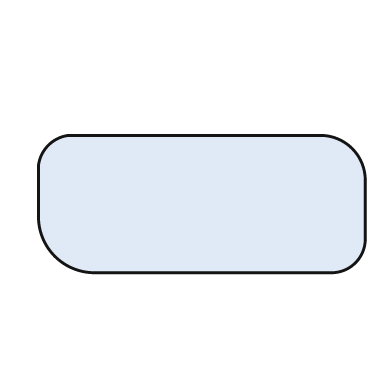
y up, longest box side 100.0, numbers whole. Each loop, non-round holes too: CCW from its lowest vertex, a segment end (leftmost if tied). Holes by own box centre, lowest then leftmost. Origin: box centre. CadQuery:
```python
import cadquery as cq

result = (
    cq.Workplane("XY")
    .moveTo(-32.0, -21.0)
    .lineTo(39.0, -21.0)
    .threePointArc((47.0, -18.0), (50.0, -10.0))
    .lineTo(50.0, 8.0)
    .threePointArc((46.0, 17.0), (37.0, 21.0))
    .lineTo(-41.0, 21.0)
    .threePointArc((-47.0, 18.0), (-50.0, 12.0))
    .lineTo(-50.0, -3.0)
    .threePointArc((-45.0, -16.0), (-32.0, -21.0))
    .close()
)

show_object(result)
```